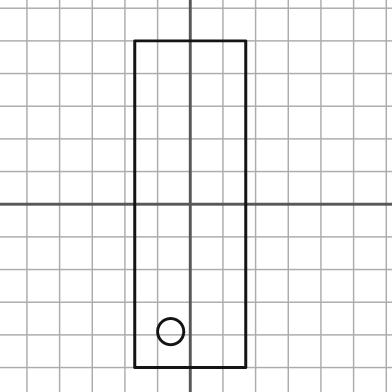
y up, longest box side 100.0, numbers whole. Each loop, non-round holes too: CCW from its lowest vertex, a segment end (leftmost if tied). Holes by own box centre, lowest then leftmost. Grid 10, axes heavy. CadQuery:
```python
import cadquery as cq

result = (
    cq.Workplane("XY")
    .moveTo(-17.0, -50.0)
    .lineTo(17.0, -50.0)
    .lineTo(17.0, 50.0)
    .lineTo(-17.0, 50.0)
    .close()
    .moveTo(-6.0, -39.0)
    .circle(4.0)
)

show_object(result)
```